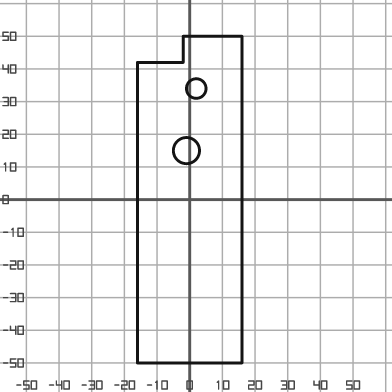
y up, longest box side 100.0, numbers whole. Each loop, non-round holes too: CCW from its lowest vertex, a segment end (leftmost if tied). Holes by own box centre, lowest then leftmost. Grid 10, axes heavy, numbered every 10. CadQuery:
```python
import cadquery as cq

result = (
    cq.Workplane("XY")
    .moveTo(-16.0, -50.0)
    .lineTo(16.0, -50.0)
    .lineTo(16.0, 50.0)
    .lineTo(-2.0, 50.0)
    .lineTo(-2.0, 42.0)
    .lineTo(-16.0, 42.0)
    .close()
    .moveTo(-1.0, 15.0)
    .circle(4.0)
    .moveTo(2.0, 34.0)
    .circle(3.0)
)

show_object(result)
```